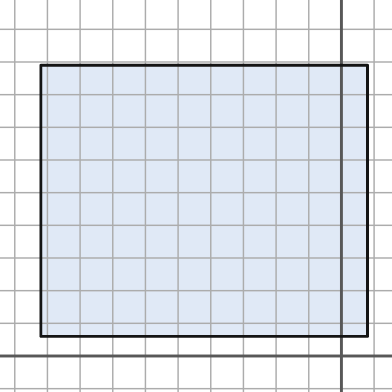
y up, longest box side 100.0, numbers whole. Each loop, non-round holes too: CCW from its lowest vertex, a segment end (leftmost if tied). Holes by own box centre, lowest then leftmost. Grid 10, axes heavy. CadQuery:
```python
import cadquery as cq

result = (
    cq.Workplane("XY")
    .moveTo(-92.0, 6.0)
    .lineTo(8.0, 6.0)
    .lineTo(8.0, 89.0)
    .lineTo(-92.0, 89.0)
    .close()
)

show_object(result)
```